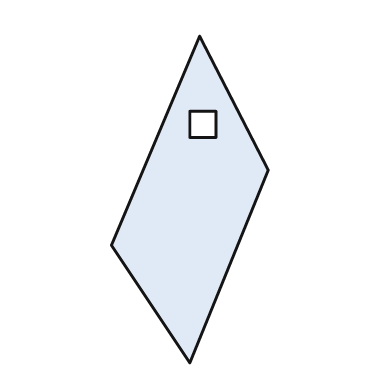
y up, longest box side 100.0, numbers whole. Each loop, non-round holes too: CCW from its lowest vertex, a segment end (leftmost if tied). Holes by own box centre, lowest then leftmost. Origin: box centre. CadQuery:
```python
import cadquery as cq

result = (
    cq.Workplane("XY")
    .moveTo(0.0, -50.0)
    .lineTo(24.0, 9.0)
    .lineTo(3.0, 50.0)
    .lineTo(-24.0, -14.0)
    .close()
    .moveTo(0.0, 19.0)
    .lineTo(8.0, 19.0)
    .lineTo(8.0, 27.0)
    .lineTo(0.0, 27.0)
    .close()
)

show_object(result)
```